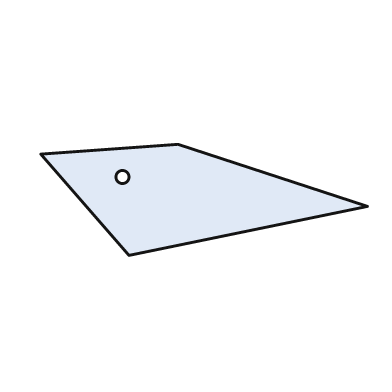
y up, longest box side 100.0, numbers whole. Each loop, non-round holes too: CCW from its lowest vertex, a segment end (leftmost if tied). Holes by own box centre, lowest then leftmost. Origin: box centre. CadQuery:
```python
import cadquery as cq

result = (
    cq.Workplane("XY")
    .moveTo(-23.0, -17.0)
    .lineTo(50.0, -2.0)
    .lineTo(-8.0, 17.0)
    .lineTo(-50.0, 14.0)
    .close()
    .moveTo(-25.0, 7.0)
    .circle(2.0)
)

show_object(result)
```